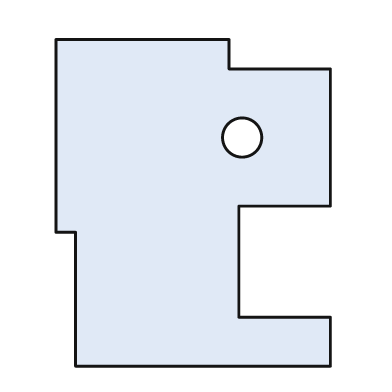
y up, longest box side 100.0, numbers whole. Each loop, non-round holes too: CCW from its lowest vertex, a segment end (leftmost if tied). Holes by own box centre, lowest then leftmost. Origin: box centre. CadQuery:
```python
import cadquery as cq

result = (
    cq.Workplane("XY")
    .moveTo(-36.0, -50.0)
    .lineTo(42.0, -50.0)
    .lineTo(42.0, -35.0)
    .lineTo(14.0, -35.0)
    .lineTo(14.0, -1.0)
    .lineTo(42.0, -1.0)
    .lineTo(42.0, 41.0)
    .lineTo(11.0, 41.0)
    .lineTo(11.0, 50.0)
    .lineTo(-42.0, 50.0)
    .lineTo(-42.0, -9.0)
    .lineTo(-36.0, -9.0)
    .close()
    .moveTo(15.0, 20.0)
    .circle(6.0)
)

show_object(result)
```